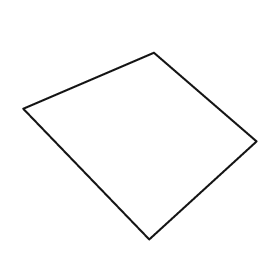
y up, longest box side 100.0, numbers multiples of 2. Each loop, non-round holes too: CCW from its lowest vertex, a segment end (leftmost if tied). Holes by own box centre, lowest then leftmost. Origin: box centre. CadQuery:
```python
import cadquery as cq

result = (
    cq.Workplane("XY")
    .moveTo(4.0, -40.0)
    .lineTo(50.0, 2.0)
    .lineTo(6.0, 40.0)
    .lineTo(-50.0, 16.0)
    .close()
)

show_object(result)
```